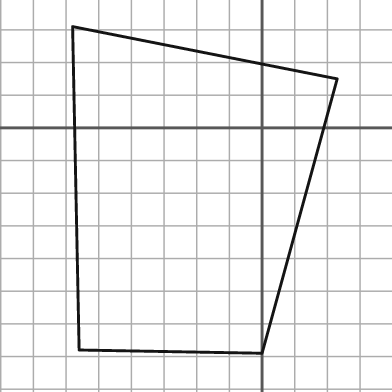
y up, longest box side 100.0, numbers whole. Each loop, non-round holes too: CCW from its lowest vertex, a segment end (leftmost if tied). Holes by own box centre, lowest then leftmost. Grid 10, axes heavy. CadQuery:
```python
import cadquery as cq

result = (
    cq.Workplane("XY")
    .moveTo(0.0, -69.0)
    .lineTo(23.0, 15.0)
    .lineTo(-58.0, 31.0)
    .lineTo(-56.0, -68.0)
    .close()
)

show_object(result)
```